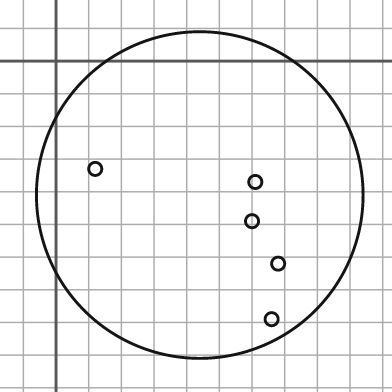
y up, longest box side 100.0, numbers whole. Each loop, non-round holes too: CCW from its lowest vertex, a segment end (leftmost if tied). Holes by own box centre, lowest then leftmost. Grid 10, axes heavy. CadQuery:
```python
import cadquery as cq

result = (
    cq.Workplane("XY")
    .moveTo(44.0, -41.0)
    .circle(50.0)
    .moveTo(66.0, -79.0)
    .circle(2.0)
    .moveTo(68.0, -62.0)
    .circle(2.0)
    .moveTo(60.0, -49.0)
    .circle(2.0)
    .moveTo(61.0, -37.0)
    .circle(2.0)
    .moveTo(12.0, -33.0)
    .circle(2.0)
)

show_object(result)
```